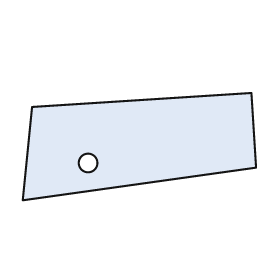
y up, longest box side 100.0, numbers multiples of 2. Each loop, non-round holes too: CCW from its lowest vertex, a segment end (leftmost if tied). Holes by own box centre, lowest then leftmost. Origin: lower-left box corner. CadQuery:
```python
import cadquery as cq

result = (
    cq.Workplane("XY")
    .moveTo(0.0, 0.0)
    .lineTo(100.0, 14.0)
    .lineTo(98.0, 46.0)
    .lineTo(4.0, 40.0)
    .close()
    .moveTo(28.0, 16.0)
    .circle(4.0)
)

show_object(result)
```